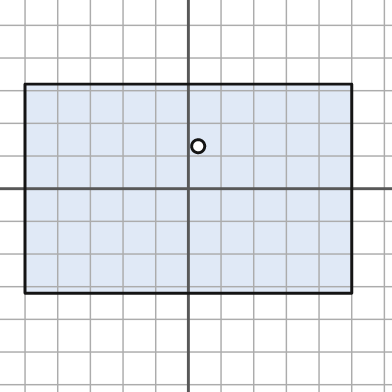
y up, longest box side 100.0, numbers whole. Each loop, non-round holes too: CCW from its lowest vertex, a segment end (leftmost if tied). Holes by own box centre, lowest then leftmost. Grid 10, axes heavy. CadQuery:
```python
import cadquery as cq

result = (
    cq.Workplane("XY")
    .moveTo(-50.0, -32.0)
    .lineTo(50.0, -32.0)
    .lineTo(50.0, 32.0)
    .lineTo(-50.0, 32.0)
    .close()
    .moveTo(3.0, 13.0)
    .circle(2.0)
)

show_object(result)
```